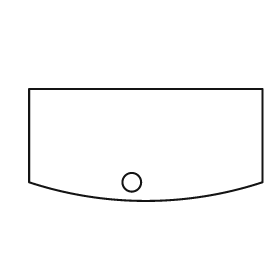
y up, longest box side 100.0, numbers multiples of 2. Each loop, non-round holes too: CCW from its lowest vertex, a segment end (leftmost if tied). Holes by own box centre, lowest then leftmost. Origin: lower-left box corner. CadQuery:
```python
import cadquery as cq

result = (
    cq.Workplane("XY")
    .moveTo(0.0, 8.0)
    .threePointArc((50.0, 0.0), (100.0, 8.0))
    .lineTo(100.0, 48.0)
    .lineTo(0.0, 48.0)
    .close()
    .moveTo(44.0, 8.0)
    .circle(4.0)
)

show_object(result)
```